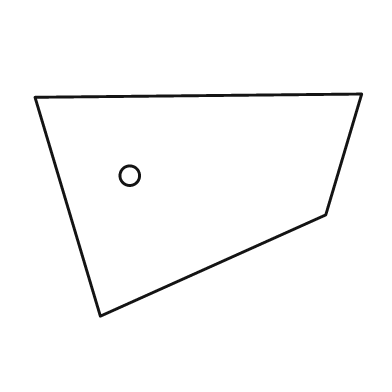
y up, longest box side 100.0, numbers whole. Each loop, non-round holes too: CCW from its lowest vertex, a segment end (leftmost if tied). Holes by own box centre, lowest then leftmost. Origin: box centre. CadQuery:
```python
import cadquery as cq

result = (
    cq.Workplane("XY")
    .moveTo(-30.0, -34.0)
    .lineTo(39.0, -3.0)
    .lineTo(50.0, 34.0)
    .lineTo(-50.0, 33.0)
    .close()
    .moveTo(-21.0, 9.0)
    .circle(3.0)
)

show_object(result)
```